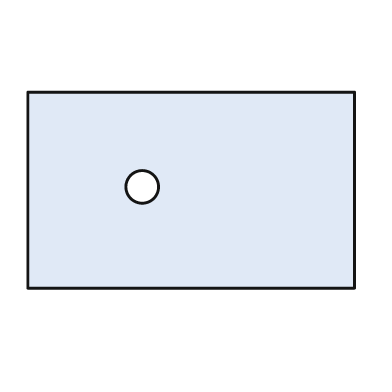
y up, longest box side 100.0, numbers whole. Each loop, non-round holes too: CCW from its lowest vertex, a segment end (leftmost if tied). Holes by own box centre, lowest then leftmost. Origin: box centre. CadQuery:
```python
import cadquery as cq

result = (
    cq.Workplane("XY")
    .moveTo(-50.0, -30.0)
    .lineTo(50.0, -30.0)
    .lineTo(50.0, 30.0)
    .lineTo(-50.0, 30.0)
    .close()
    .moveTo(-15.0, 1.0)
    .circle(5.0)
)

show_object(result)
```